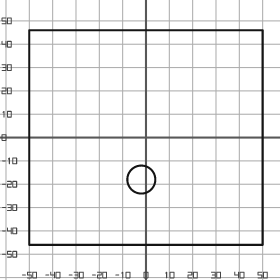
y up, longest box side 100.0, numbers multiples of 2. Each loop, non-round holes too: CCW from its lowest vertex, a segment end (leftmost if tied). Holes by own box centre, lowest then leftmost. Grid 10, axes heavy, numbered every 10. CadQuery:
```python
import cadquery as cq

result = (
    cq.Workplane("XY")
    .moveTo(-50.0, -46.0)
    .lineTo(50.0, -46.0)
    .lineTo(50.0, 46.0)
    .lineTo(-50.0, 46.0)
    .close()
    .moveTo(-2.0, -18.0)
    .circle(6.0)
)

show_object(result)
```